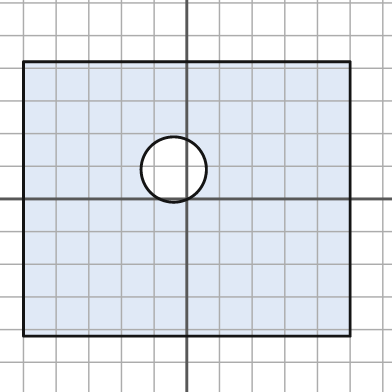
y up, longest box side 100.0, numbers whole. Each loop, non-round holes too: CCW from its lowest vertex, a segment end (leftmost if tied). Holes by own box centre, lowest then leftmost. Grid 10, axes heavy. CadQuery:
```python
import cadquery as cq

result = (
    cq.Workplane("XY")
    .moveTo(-50.0, -42.0)
    .lineTo(50.0, -42.0)
    .lineTo(50.0, 42.0)
    .lineTo(-50.0, 42.0)
    .close()
    .moveTo(-4.0, 9.0)
    .circle(10.0)
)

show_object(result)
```